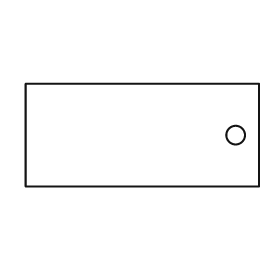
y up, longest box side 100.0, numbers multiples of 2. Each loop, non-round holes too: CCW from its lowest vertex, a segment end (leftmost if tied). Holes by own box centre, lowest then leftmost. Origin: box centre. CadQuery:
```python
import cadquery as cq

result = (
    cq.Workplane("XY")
    .moveTo(-50.0, -22.0)
    .lineTo(50.0, -22.0)
    .lineTo(50.0, 22.0)
    .lineTo(-50.0, 22.0)
    .close()
    .moveTo(40.0, 0.0)
    .circle(4.0)
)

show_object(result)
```